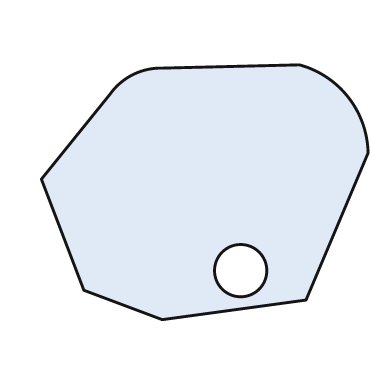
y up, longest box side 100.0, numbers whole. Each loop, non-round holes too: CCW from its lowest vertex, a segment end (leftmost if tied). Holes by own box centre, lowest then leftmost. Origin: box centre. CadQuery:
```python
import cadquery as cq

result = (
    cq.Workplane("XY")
    .moveTo(-13.0, -39.0)
    .lineTo(31.0, -33.0)
    .lineTo(50.0, 12.0)
    .threePointArc((44.0, 29.0), (29.0, 39.0))
    .lineTo(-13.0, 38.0)
    .threePointArc((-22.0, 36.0), (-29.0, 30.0))
    .lineTo(-50.0, 4.0)
    .lineTo(-37.0, -30.0)
    .close()
    .moveTo(11.0, -24.0)
    .circle(8.0)
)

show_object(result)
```